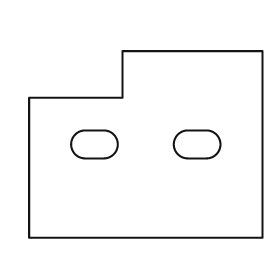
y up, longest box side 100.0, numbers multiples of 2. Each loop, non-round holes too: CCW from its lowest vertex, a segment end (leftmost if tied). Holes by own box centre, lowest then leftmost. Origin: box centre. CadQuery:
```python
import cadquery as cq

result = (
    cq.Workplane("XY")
    .moveTo(-50.0, -40.0)
    .lineTo(50.0, -40.0)
    .lineTo(50.0, 40.0)
    .lineTo(-10.0, 40.0)
    .lineTo(-10.0, 20.0)
    .lineTo(-50.0, 20.0)
    .close()
    .moveTo(-26.0, -6.0)
    .lineTo(-18.0, -6.0)
    .threePointArc((-12.0, 0.0), (-18.0, 6.0))
    .lineTo(-26.0, 6.0)
    .threePointArc((-32.0, 0.0), (-26.0, -6.0))
    .close()
    .moveTo(18.0, -6.0)
    .lineTo(26.0, -6.0)
    .threePointArc((32.0, 0.0), (26.0, 6.0))
    .lineTo(18.0, 6.0)
    .threePointArc((12.0, 0.0), (18.0, -6.0))
    .close()
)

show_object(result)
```